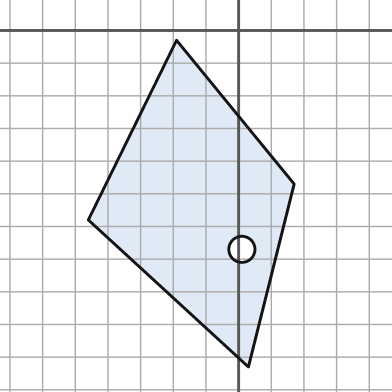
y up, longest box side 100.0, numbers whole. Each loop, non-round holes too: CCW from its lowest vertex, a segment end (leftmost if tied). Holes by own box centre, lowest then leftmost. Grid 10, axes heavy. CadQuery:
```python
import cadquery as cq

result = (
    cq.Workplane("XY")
    .moveTo(3.0, -103.0)
    .lineTo(17.0, -47.0)
    .lineTo(-19.0, -3.0)
    .lineTo(-46.0, -58.0)
    .close()
    .moveTo(1.0, -67.0)
    .circle(4.0)
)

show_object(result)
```